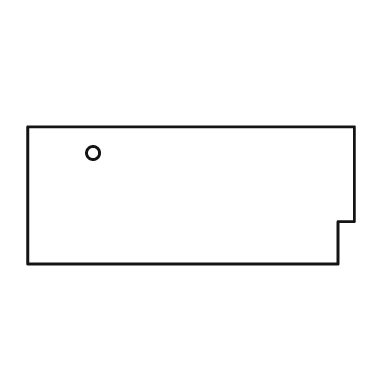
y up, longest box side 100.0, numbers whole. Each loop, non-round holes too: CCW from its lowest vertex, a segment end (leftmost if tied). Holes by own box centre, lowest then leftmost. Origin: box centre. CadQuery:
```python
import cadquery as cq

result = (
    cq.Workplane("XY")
    .moveTo(-50.0, -21.0)
    .lineTo(45.0, -21.0)
    .lineTo(45.0, -8.0)
    .lineTo(50.0, -8.0)
    .lineTo(50.0, 21.0)
    .lineTo(-50.0, 21.0)
    .close()
    .moveTo(-30.0, 13.0)
    .circle(2.0)
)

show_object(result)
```